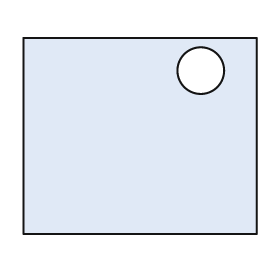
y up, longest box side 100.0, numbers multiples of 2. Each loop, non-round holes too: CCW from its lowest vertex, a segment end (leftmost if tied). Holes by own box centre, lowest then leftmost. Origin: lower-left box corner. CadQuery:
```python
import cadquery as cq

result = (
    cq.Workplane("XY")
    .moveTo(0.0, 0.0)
    .lineTo(100.0, 0.0)
    .lineTo(100.0, 84.0)
    .lineTo(0.0, 84.0)
    .close()
    .moveTo(76.0, 70.0)
    .circle(10.0)
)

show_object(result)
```